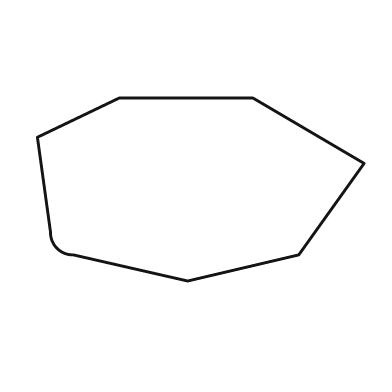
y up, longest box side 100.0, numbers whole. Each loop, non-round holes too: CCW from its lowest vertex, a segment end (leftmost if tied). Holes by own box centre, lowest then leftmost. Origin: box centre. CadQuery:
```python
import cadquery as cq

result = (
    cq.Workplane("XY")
    .moveTo(-4.0, -28.0)
    .lineTo(30.0, -20.0)
    .lineTo(50.0, 8.0)
    .lineTo(16.0, 28.0)
    .lineTo(-25.0, 28.0)
    .lineTo(-50.0, 16.0)
    .lineTo(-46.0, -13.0)
    .threePointArc((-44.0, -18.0), (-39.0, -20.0))
    .close()
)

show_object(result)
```